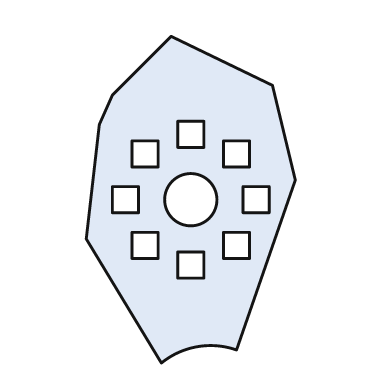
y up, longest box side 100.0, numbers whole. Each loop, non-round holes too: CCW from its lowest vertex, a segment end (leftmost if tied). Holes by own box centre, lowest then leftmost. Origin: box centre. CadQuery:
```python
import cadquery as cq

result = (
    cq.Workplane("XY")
    .moveTo(-9.0, -50.0)
    .threePointArc((2.0, -45.0), (14.0, -46.0))
    .lineTo(32.0, 6.0)
    .lineTo(25.0, 35.0)
    .lineTo(-6.0, 50.0)
    .lineTo(-24.0, 32.0)
    .lineTo(-28.0, 23.0)
    .lineTo(-32.0, -12.0)
    .close()
    .moveTo(-4.0, -24.0)
    .lineTo(4.0, -24.0)
    .lineTo(4.0, -16.0)
    .lineTo(-4.0, -16.0)
    .close()
    .moveTo(-18.0, -18.0)
    .lineTo(-10.0, -18.0)
    .lineTo(-10.0, -10.0)
    .lineTo(-18.0, -10.0)
    .close()
    .moveTo(10.0, -18.0)
    .lineTo(18.0, -18.0)
    .lineTo(18.0, -10.0)
    .lineTo(10.0, -10.0)
    .close()
    .moveTo(-24.0, -4.0)
    .lineTo(-16.0, -4.0)
    .lineTo(-16.0, 4.0)
    .lineTo(-24.0, 4.0)
    .close()
    .moveTo(0.0, 0.0)
    .circle(8.0)
    .moveTo(16.0, -4.0)
    .lineTo(24.0, -4.0)
    .lineTo(24.0, 4.0)
    .lineTo(16.0, 4.0)
    .close()
    .moveTo(-18.0, 10.0)
    .lineTo(-10.0, 10.0)
    .lineTo(-10.0, 18.0)
    .lineTo(-18.0, 18.0)
    .close()
    .moveTo(10.0, 10.0)
    .lineTo(18.0, 10.0)
    .lineTo(18.0, 18.0)
    .lineTo(10.0, 18.0)
    .close()
    .moveTo(-4.0, 16.0)
    .lineTo(4.0, 16.0)
    .lineTo(4.0, 24.0)
    .lineTo(-4.0, 24.0)
    .close()
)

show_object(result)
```